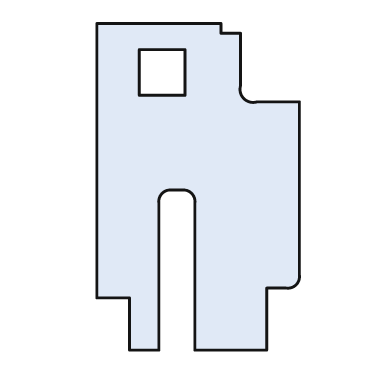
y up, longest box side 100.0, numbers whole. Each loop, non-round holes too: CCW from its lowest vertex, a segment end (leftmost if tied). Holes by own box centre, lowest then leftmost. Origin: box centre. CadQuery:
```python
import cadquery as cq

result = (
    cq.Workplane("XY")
    .moveTo(-21.0, -50.0)
    .lineTo(-12.0, -50.0)
    .lineTo(-12.0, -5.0)
    .threePointArc((-11.0, -2.0), (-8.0, -1.0))
    .lineTo(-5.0, -1.0)
    .threePointArc((-2.0, -2.0), (-1.0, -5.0))
    .lineTo(-1.0, -50.0)
    .lineTo(21.0, -50.0)
    .lineTo(21.0, -31.0)
    .lineTo(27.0, -31.0)
    .threePointArc((30.0, -30.0), (31.0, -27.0))
    .lineTo(31.0, 26.0)
    .lineTo(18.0, 26.0)
    .threePointArc((14.0, 27.0), (13.0, 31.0))
    .lineTo(13.0, 47.0)
    .lineTo(7.0, 47.0)
    .lineTo(7.0, 50.0)
    .lineTo(-31.0, 50.0)
    .lineTo(-31.0, -34.0)
    .lineTo(-21.0, -34.0)
    .close()
    .moveTo(-18.0, 28.0)
    .lineTo(-4.0, 28.0)
    .lineTo(-4.0, 42.0)
    .lineTo(-18.0, 42.0)
    .close()
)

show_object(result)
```